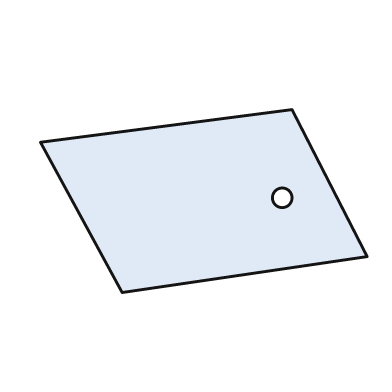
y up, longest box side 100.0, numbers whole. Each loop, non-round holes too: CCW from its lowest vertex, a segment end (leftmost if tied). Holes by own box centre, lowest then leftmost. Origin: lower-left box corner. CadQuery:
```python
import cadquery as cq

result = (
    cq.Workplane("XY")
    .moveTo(25.0, 0.0)
    .lineTo(100.0, 11.0)
    .lineTo(77.0, 56.0)
    .lineTo(0.0, 46.0)
    .close()
    .moveTo(74.0, 29.0)
    .circle(3.0)
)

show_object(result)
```